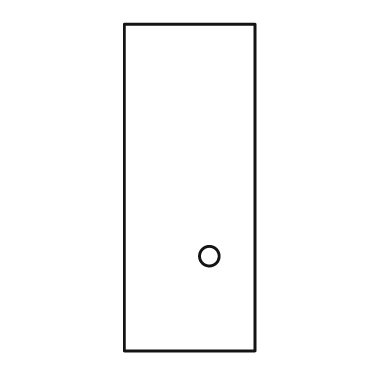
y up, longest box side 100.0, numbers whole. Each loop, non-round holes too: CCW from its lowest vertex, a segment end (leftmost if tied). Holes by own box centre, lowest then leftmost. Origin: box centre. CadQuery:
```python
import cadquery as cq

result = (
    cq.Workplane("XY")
    .moveTo(-20.0, -50.0)
    .lineTo(20.0, -50.0)
    .lineTo(20.0, 50.0)
    .lineTo(-20.0, 50.0)
    .close()
    .moveTo(6.0, -21.0)
    .circle(3.0)
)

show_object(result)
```